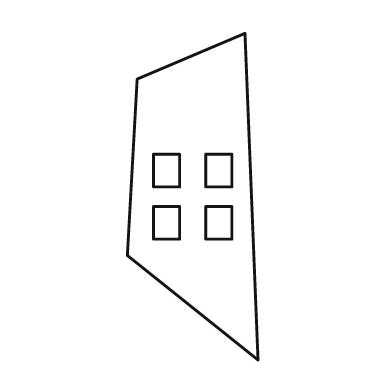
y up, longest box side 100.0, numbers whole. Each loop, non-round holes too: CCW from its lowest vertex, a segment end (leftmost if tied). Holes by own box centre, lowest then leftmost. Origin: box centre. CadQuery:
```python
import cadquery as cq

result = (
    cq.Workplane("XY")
    .moveTo(20.0, -50.0)
    .lineTo(16.0, 50.0)
    .lineTo(-17.0, 36.0)
    .lineTo(-20.0, -18.0)
    .close()
    .moveTo(-12.0, -13.0)
    .lineTo(-4.0, -13.0)
    .lineTo(-4.0, -3.0)
    .lineTo(-12.0, -3.0)
    .close()
    .moveTo(4.0, -13.0)
    .lineTo(12.0, -13.0)
    .lineTo(12.0, -3.0)
    .lineTo(4.0, -3.0)
    .close()
    .moveTo(-12.0, 3.0)
    .lineTo(-4.0, 3.0)
    .lineTo(-4.0, 13.0)
    .lineTo(-12.0, 13.0)
    .close()
    .moveTo(4.0, 3.0)
    .lineTo(12.0, 3.0)
    .lineTo(12.0, 13.0)
    .lineTo(4.0, 13.0)
    .close()
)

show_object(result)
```